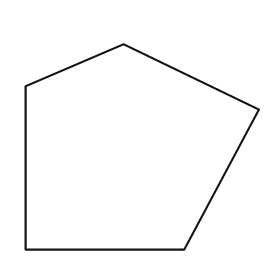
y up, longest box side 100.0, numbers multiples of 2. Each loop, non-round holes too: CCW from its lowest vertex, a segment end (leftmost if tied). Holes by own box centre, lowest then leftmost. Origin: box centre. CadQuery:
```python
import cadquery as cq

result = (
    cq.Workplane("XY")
    .moveTo(-50.0, -44.0)
    .lineTo(18.0, -44.0)
    .lineTo(50.0, 16.0)
    .lineTo(-8.0, 44.0)
    .lineTo(-50.0, 26.0)
    .close()
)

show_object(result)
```